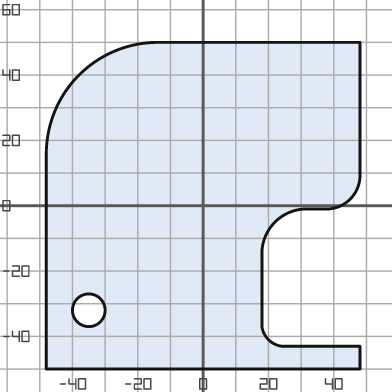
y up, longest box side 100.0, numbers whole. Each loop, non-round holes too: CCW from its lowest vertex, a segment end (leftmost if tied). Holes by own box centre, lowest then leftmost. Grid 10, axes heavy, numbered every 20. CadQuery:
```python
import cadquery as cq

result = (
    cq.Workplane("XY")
    .moveTo(-48.0, -50.0)
    .lineTo(48.0, -50.0)
    .lineTo(48.0, -43.0)
    .lineTo(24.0, -43.0)
    .threePointArc((20.0, -41.0), (18.0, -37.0))
    .lineTo(18.0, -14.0)
    .threePointArc((22.0, -5.0), (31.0, -1.0))
    .lineTo(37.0, -1.0)
    .threePointArc((45.0, 2.0), (48.0, 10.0))
    .lineTo(48.0, 50.0)
    .lineTo(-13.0, 50.0)
    .threePointArc((-38.0, 40.0), (-48.0, 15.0))
    .close()
    .moveTo(-35.0, -32.0)
    .circle(5.0)
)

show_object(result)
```